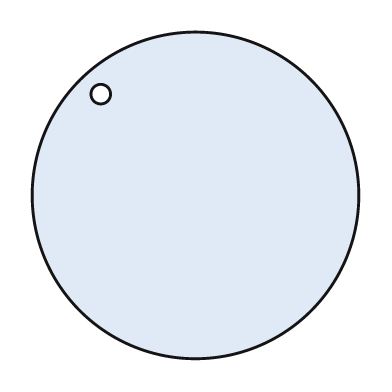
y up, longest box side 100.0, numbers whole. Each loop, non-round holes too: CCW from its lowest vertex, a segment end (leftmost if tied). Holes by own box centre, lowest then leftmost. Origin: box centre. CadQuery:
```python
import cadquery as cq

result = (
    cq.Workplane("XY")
    .moveTo(0.0, 0.0)
    .circle(50.0)
    .moveTo(-29.0, 31.0)
    .circle(3.0)
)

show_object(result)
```